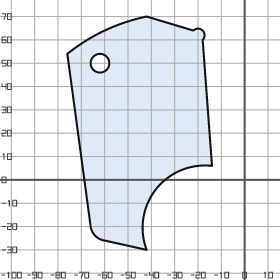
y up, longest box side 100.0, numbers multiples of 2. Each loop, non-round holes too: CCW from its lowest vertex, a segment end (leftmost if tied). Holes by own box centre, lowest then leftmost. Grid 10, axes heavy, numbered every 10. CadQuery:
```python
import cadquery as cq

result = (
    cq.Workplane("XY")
    .moveTo(-42.0, -30.0)
    .threePointArc((-38.0, -4.0), (-14.0, 6.0))
    .lineTo(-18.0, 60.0)
    .threePointArc((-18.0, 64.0), (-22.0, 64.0))
    .lineTo(-42.0, 70.0)
    .threePointArc((-60.0, 64.0), (-76.0, 54.0))
    .lineTo(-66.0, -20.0)
    .threePointArc((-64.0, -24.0), (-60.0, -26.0))
    .close()
    .moveTo(-62.0, 50.0)
    .circle(4.0)
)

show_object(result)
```